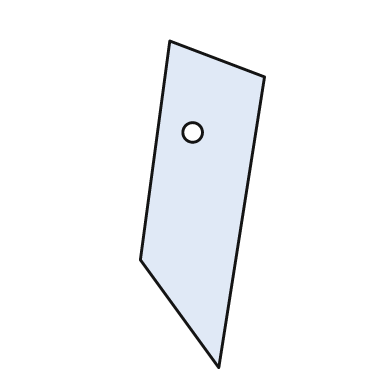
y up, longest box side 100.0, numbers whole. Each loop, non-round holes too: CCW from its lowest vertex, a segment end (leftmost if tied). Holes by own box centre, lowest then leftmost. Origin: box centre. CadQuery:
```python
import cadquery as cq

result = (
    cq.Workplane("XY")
    .moveTo(5.0, -50.0)
    .lineTo(19.0, 39.0)
    .lineTo(-10.0, 50.0)
    .lineTo(-19.0, -17.0)
    .close()
    .moveTo(-3.0, 22.0)
    .circle(3.0)
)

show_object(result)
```